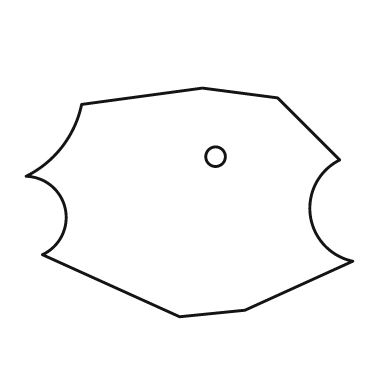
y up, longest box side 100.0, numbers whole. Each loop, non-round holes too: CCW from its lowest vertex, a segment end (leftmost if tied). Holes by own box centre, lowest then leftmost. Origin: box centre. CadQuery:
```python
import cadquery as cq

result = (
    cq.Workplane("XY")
    .moveTo(-3.0, -35.0)
    .lineTo(17.0, -33.0)
    .lineTo(50.0, -18.0)
    .threePointArc((37.0, -4.0), (46.0, 13.0))
    .lineTo(27.0, 32.0)
    .lineTo(4.0, 35.0)
    .lineTo(-33.0, 30.0)
    .threePointArc((-39.0, 17.0), (-50.0, 8.0))
    .threePointArc((-38.0, -2.0), (-45.0, -16.0))
    .close()
    .moveTo(8.0, 14.0)
    .circle(3.0)
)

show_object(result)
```